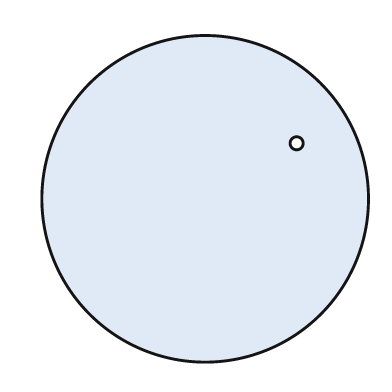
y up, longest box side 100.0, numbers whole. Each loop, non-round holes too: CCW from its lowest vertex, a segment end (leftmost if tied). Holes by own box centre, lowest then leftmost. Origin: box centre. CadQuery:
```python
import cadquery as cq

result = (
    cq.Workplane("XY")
    .moveTo(0.0, 0.0)
    .circle(50.0)
    .moveTo(28.0, 17.0)
    .circle(2.0)
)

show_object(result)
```